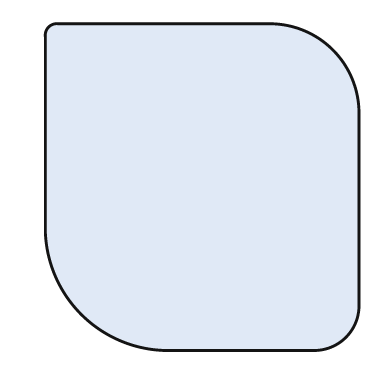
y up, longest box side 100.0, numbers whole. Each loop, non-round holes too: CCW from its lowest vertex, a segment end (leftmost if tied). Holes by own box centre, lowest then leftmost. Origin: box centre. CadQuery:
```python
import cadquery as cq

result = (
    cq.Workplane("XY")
    .moveTo(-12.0, -50.0)
    .lineTo(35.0, -50.0)
    .threePointArc((44.0, -46.0), (48.0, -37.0))
    .lineTo(48.0, 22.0)
    .threePointArc((40.0, 42.0), (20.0, 50.0))
    .lineTo(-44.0, 50.0)
    .threePointArc((-47.0, 49.0), (-48.0, 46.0))
    .lineTo(-48.0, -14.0)
    .threePointArc((-37.0, -39.0), (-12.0, -50.0))
    .close()
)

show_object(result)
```